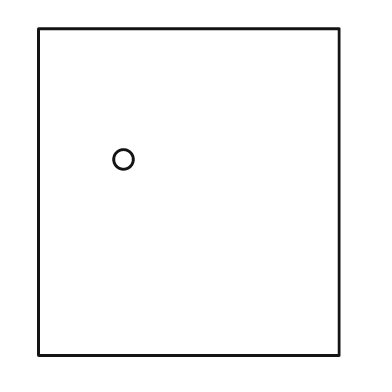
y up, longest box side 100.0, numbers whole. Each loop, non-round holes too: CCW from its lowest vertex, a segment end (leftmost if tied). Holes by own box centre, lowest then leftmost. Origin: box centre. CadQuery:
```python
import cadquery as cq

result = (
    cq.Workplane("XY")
    .moveTo(-46.0, -50.0)
    .lineTo(46.0, -50.0)
    .lineTo(46.0, 50.0)
    .lineTo(-46.0, 50.0)
    .close()
    .moveTo(-20.0, 10.0)
    .circle(3.0)
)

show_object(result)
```